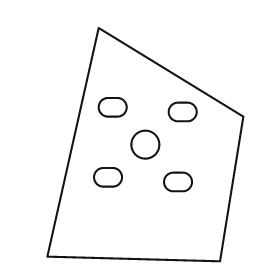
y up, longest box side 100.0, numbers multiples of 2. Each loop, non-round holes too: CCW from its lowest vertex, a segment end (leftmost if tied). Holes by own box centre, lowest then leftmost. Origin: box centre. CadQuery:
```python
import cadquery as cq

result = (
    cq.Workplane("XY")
    .moveTo(32.0, -50.0)
    .lineTo(42.0, 12.0)
    .lineTo(-20.0, 50.0)
    .lineTo(-42.0, -48.0)
    .close()
    .moveTo(12.0, -20.0)
    .lineTo(16.0, -20.0)
    .threePointArc((20.0, -16.0), (16.0, -12.0))
    .lineTo(12.0, -12.0)
    .threePointArc((8.0, -16.0), (12.0, -20.0))
    .close()
    .moveTo(-18.0, -18.0)
    .lineTo(-14.0, -18.0)
    .threePointArc((-10.0, -14.0), (-14.0, -10.0))
    .lineTo(-18.0, -10.0)
    .threePointArc((-22.0, -14.0), (-18.0, -18.0))
    .close()
    .moveTo(0.0, 0.0)
    .circle(6.0)
    .moveTo(14.0, 10.0)
    .lineTo(18.0, 10.0)
    .threePointArc((22.0, 14.0), (18.0, 18.0))
    .lineTo(14.0, 18.0)
    .threePointArc((10.0, 14.0), (14.0, 10.0))
    .close()
    .moveTo(-16.0, 12.0)
    .lineTo(-12.0, 12.0)
    .threePointArc((-8.0, 16.0), (-12.0, 20.0))
    .lineTo(-16.0, 20.0)
    .threePointArc((-20.0, 16.0), (-16.0, 12.0))
    .close()
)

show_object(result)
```